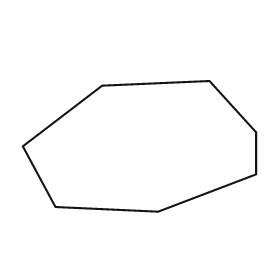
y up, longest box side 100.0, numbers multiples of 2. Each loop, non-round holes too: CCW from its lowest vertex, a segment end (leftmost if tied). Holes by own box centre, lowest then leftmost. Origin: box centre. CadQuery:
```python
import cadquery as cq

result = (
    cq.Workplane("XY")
    .moveTo(8.0, -28.0)
    .lineTo(50.0, -12.0)
    .lineTo(50.0, 6.0)
    .lineTo(30.0, 28.0)
    .lineTo(-16.0, 26.0)
    .lineTo(-50.0, 0.0)
    .lineTo(-36.0, -26.0)
    .close()
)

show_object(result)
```